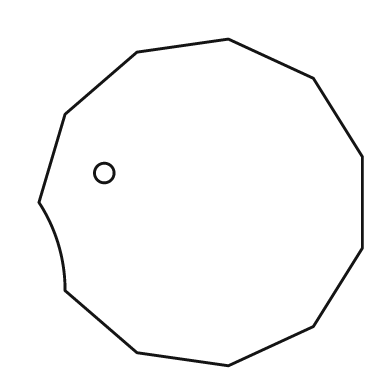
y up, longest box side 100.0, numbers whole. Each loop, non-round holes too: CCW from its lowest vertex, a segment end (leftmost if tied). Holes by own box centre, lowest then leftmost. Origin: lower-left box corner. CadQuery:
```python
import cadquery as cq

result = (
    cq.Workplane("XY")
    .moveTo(58.0, 0.0)
    .lineTo(84.0, 12.0)
    .lineTo(99.0, 36.0)
    .lineTo(99.0, 64.0)
    .lineTo(84.0, 88.0)
    .lineTo(58.0, 100.0)
    .lineTo(30.0, 96.0)
    .lineTo(8.0, 77.0)
    .lineTo(0.0, 50.0)
    .threePointArc((6.0, 37.0), (8.0, 23.0))
    .lineTo(30.0, 4.0)
    .close()
    .moveTo(20.0, 59.0)
    .circle(3.0)
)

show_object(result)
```